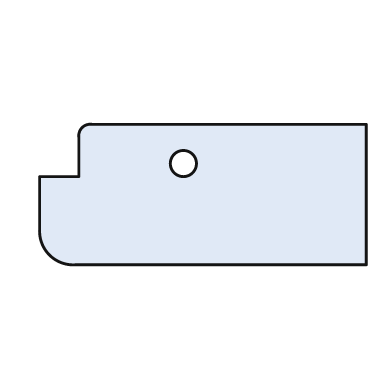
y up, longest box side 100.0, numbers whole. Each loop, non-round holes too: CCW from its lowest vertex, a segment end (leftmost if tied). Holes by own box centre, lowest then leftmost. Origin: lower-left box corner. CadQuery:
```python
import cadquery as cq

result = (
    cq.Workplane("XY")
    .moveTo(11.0, 0.0)
    .lineTo(100.0, 0.0)
    .lineTo(100.0, 43.0)
    .lineTo(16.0, 43.0)
    .threePointArc((13.0, 42.0), (12.0, 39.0))
    .lineTo(12.0, 27.0)
    .lineTo(0.0, 27.0)
    .lineTo(0.0, 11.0)
    .threePointArc((3.0, 3.0), (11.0, 0.0))
    .close()
    .moveTo(44.0, 31.0)
    .circle(4.0)
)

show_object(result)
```